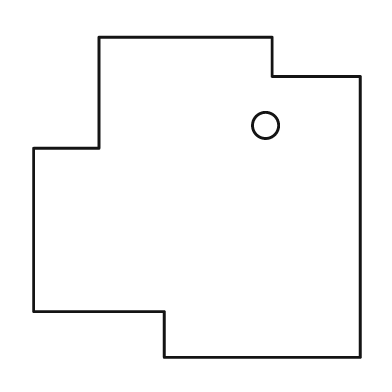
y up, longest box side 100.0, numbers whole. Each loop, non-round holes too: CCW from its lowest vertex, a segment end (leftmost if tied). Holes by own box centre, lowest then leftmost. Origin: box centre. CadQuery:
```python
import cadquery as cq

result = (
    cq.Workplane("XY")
    .moveTo(-10.0, -49.0)
    .lineTo(50.0, -49.0)
    .lineTo(50.0, 37.0)
    .lineTo(23.0, 37.0)
    .lineTo(23.0, 49.0)
    .lineTo(-30.0, 49.0)
    .lineTo(-30.0, 15.0)
    .lineTo(-50.0, 15.0)
    .lineTo(-50.0, -35.0)
    .lineTo(-10.0, -35.0)
    .close()
    .moveTo(21.0, 22.0)
    .circle(4.0)
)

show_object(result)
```